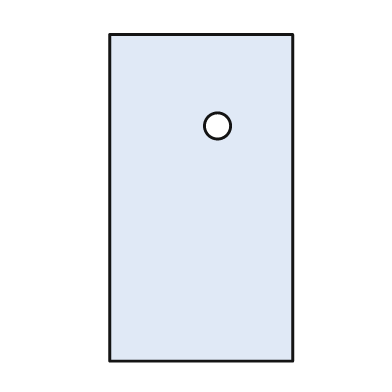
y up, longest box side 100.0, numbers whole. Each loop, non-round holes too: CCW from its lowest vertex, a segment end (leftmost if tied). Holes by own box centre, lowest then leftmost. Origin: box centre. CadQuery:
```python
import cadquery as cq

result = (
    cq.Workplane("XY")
    .moveTo(-28.0, -50.0)
    .lineTo(28.0, -50.0)
    .lineTo(28.0, 50.0)
    .lineTo(-28.0, 50.0)
    .close()
    .moveTo(5.0, 22.0)
    .circle(4.0)
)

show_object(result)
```